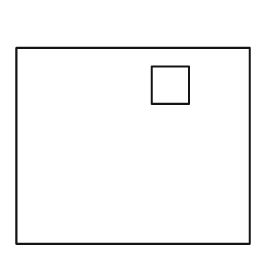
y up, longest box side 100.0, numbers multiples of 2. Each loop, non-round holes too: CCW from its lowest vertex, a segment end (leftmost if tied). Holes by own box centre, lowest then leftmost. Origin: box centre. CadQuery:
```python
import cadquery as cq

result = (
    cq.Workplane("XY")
    .moveTo(-50.0, -42.0)
    .lineTo(50.0, -42.0)
    .lineTo(50.0, 42.0)
    .lineTo(-50.0, 42.0)
    .close()
    .moveTo(8.0, 18.0)
    .lineTo(24.0, 18.0)
    .lineTo(24.0, 34.0)
    .lineTo(8.0, 34.0)
    .close()
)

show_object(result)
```